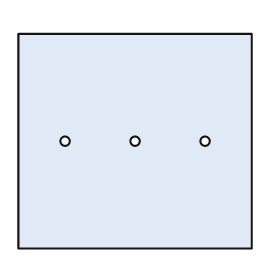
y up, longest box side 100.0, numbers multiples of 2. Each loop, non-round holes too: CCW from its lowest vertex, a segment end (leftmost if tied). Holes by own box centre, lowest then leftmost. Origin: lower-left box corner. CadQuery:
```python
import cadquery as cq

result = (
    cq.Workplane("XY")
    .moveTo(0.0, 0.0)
    .lineTo(100.0, 0.0)
    .lineTo(100.0, 92.0)
    .lineTo(0.0, 92.0)
    .close()
    .moveTo(20.0, 46.0)
    .circle(2.0)
    .moveTo(50.0, 46.0)
    .circle(2.0)
    .moveTo(80.0, 46.0)
    .circle(2.0)
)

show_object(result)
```